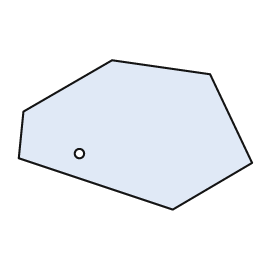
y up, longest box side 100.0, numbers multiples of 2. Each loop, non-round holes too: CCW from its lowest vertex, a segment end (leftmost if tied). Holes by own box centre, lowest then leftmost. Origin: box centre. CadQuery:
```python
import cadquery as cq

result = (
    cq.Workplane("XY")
    .moveTo(16.0, -32.0)
    .lineTo(50.0, -12.0)
    .lineTo(32.0, 26.0)
    .lineTo(-10.0, 32.0)
    .lineTo(-48.0, 10.0)
    .lineTo(-50.0, -10.0)
    .close()
    .moveTo(-24.0, -8.0)
    .circle(2.0)
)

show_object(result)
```